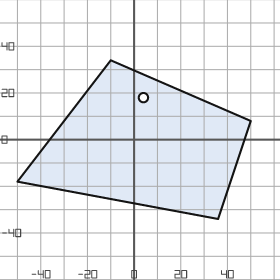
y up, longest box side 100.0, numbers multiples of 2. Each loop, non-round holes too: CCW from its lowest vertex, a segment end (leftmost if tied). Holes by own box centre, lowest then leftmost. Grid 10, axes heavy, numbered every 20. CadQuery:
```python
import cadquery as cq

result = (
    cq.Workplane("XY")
    .moveTo(36.0, -34.0)
    .lineTo(50.0, 8.0)
    .lineTo(-10.0, 34.0)
    .lineTo(-50.0, -18.0)
    .close()
    .moveTo(4.0, 18.0)
    .circle(2.0)
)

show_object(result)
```